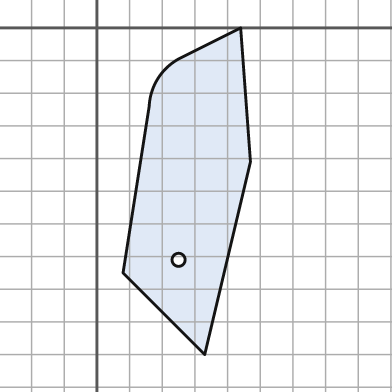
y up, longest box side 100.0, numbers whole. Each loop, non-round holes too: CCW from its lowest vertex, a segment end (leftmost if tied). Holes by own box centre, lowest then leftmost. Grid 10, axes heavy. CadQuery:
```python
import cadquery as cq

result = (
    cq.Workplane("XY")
    .moveTo(33.0, -100.0)
    .lineTo(47.0, -41.0)
    .lineTo(44.0, 0.0)
    .lineTo(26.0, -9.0)
    .threePointArc((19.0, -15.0), (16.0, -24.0))
    .lineTo(8.0, -75.0)
    .close()
    .moveTo(25.0, -71.0)
    .circle(2.0)
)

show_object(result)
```